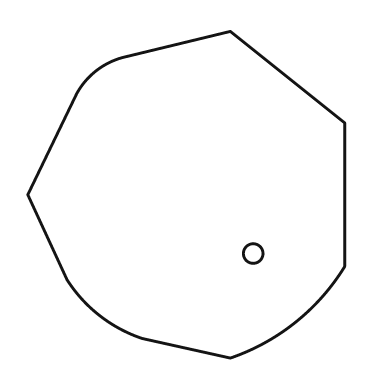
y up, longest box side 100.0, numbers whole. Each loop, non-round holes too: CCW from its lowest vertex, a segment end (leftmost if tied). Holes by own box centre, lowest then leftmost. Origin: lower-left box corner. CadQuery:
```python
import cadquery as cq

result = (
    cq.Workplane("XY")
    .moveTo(62.0, 0.0)
    .threePointArc((82.0, 11.0), (97.0, 28.0))
    .lineTo(97.0, 72.0)
    .lineTo(62.0, 100.0)
    .lineTo(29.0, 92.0)
    .threePointArc((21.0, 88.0), (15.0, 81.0))
    .lineTo(0.0, 50.0)
    .lineTo(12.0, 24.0)
    .threePointArc((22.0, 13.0), (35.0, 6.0))
    .close()
    .moveTo(69.0, 32.0)
    .circle(3.0)
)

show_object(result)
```